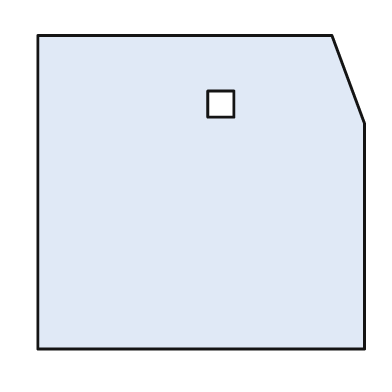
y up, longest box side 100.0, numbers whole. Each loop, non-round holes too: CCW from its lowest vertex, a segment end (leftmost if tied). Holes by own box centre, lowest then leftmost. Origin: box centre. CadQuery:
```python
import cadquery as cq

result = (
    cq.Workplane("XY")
    .moveTo(-50.0, -48.0)
    .lineTo(50.0, -48.0)
    .lineTo(50.0, 21.0)
    .lineTo(40.0, 48.0)
    .lineTo(-50.0, 48.0)
    .close()
    .moveTo(2.0, 23.0)
    .lineTo(10.0, 23.0)
    .lineTo(10.0, 31.0)
    .lineTo(2.0, 31.0)
    .close()
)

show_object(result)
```